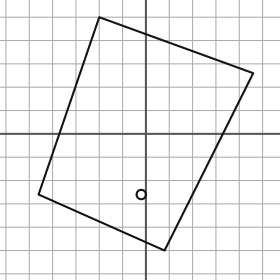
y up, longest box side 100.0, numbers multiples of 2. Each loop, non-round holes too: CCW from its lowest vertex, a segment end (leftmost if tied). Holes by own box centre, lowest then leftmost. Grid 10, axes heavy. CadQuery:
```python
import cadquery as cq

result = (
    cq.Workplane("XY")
    .moveTo(8.0, -50.0)
    .lineTo(46.0, 26.0)
    .lineTo(-20.0, 50.0)
    .lineTo(-46.0, -26.0)
    .close()
    .moveTo(-2.0, -26.0)
    .circle(2.0)
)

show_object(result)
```